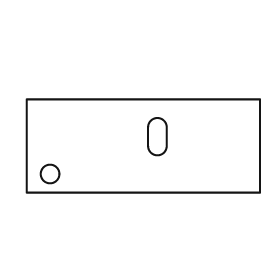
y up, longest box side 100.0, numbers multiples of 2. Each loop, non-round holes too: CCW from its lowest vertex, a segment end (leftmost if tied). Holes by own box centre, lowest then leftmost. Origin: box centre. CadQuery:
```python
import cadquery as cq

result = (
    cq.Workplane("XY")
    .moveTo(-50.0, -20.0)
    .lineTo(50.0, -20.0)
    .lineTo(50.0, 20.0)
    .lineTo(-50.0, 20.0)
    .close()
    .moveTo(-40.0, -12.0)
    .circle(4.0)
    .moveTo(2.0, 0.0)
    .threePointArc((6.0, -4.0), (10.0, 0.0))
    .lineTo(10.0, 8.0)
    .threePointArc((6.0, 12.0), (2.0, 8.0))
    .close()
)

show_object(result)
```